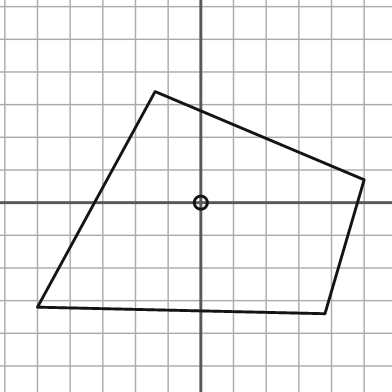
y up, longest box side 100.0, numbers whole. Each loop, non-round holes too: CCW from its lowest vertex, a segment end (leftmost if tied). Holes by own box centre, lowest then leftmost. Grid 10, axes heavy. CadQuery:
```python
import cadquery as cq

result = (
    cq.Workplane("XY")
    .moveTo(38.0, -34.0)
    .lineTo(50.0, 7.0)
    .lineTo(-14.0, 34.0)
    .lineTo(-50.0, -32.0)
    .close()
    .moveTo(0.0, 0.0)
    .circle(2.0)
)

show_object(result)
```